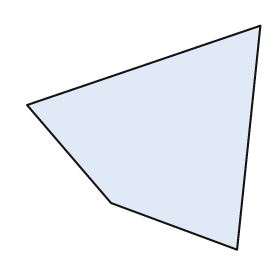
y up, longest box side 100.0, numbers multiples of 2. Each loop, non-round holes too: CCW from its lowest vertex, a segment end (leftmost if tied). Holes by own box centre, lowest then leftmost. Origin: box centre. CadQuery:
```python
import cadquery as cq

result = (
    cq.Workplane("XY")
    .moveTo(40.0, -48.0)
    .lineTo(50.0, 48.0)
    .lineTo(-50.0, 14.0)
    .lineTo(-14.0, -28.0)
    .close()
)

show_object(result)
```